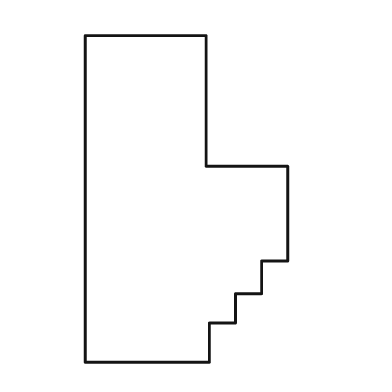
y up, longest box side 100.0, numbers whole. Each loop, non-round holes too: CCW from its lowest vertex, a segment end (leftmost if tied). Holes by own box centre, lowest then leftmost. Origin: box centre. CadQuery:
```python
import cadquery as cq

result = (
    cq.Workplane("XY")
    .moveTo(-31.0, -50.0)
    .lineTo(7.0, -50.0)
    .lineTo(7.0, -38.0)
    .lineTo(15.0, -38.0)
    .lineTo(15.0, -29.0)
    .lineTo(23.0, -29.0)
    .lineTo(23.0, -19.0)
    .lineTo(31.0, -19.0)
    .lineTo(31.0, 10.0)
    .lineTo(6.0, 10.0)
    .lineTo(6.0, 50.0)
    .lineTo(-31.0, 50.0)
    .close()
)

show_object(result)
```